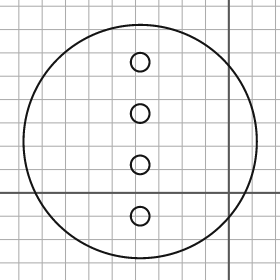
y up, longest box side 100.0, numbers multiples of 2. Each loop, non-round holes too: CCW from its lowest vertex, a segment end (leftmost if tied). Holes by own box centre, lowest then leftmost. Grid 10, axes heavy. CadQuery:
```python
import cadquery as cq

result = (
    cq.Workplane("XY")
    .moveTo(-38.0, 22.0)
    .circle(50.0)
    .moveTo(-38.0, -10.0)
    .circle(4.0)
    .moveTo(-38.0, 12.0)
    .circle(4.0)
    .moveTo(-38.0, 34.0)
    .circle(4.0)
    .moveTo(-38.0, 56.0)
    .circle(4.0)
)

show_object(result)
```